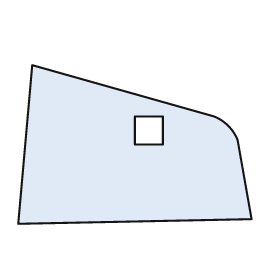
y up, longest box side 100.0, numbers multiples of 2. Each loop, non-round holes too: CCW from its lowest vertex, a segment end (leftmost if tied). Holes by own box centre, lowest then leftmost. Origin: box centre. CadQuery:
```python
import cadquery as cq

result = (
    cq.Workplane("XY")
    .moveTo(-50.0, -34.0)
    .lineTo(50.0, -32.0)
    .lineTo(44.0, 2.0)
    .threePointArc((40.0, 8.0), (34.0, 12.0))
    .lineTo(-44.0, 34.0)
    .close()
    .moveTo(0.0, 0.0)
    .lineTo(12.0, 0.0)
    .lineTo(12.0, 12.0)
    .lineTo(0.0, 12.0)
    .close()
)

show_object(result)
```